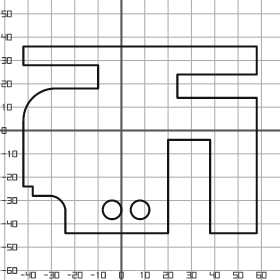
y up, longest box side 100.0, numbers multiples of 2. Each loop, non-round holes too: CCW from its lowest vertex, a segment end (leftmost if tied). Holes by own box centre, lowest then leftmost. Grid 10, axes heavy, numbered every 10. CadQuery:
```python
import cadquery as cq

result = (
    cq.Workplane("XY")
    .moveTo(-24.0, -44.0)
    .lineTo(20.0, -44.0)
    .lineTo(20.0, -4.0)
    .lineTo(38.0, -4.0)
    .lineTo(38.0, -44.0)
    .lineTo(58.0, -44.0)
    .lineTo(58.0, 14.0)
    .lineTo(24.0, 14.0)
    .lineTo(24.0, 24.0)
    .lineTo(58.0, 24.0)
    .lineTo(58.0, 36.0)
    .lineTo(-42.0, 36.0)
    .lineTo(-42.0, 28.0)
    .lineTo(-10.0, 28.0)
    .lineTo(-10.0, 18.0)
    .lineTo(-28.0, 18.0)
    .threePointArc((-38.0, 14.0), (-42.0, 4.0))
    .lineTo(-42.0, -24.0)
    .lineTo(-38.0, -24.0)
    .lineTo(-38.0, -28.0)
    .lineTo(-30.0, -28.0)
    .threePointArc((-26.0, -30.0), (-24.0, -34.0))
    .close()
    .moveTo(-4.0, -34.0)
    .circle(4.0)
    .moveTo(8.0, -34.0)
    .circle(4.0)
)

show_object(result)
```